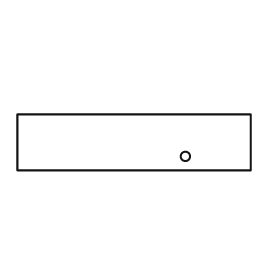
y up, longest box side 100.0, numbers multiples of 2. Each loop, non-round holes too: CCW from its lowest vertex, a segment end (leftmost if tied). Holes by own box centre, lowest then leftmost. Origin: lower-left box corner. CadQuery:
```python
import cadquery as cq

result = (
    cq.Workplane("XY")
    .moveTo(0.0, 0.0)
    .lineTo(100.0, 0.0)
    .lineTo(100.0, 24.0)
    .lineTo(0.0, 24.0)
    .close()
    .moveTo(72.0, 6.0)
    .circle(2.0)
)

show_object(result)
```